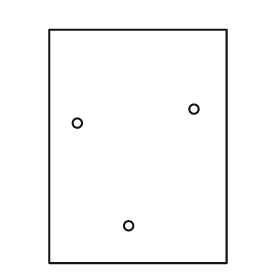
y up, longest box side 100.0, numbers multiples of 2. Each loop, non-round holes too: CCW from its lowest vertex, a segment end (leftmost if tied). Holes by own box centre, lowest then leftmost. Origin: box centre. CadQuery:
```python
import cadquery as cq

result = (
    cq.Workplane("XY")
    .moveTo(-38.0, -50.0)
    .lineTo(38.0, -50.0)
    .lineTo(38.0, 50.0)
    .lineTo(-38.0, 50.0)
    .close()
    .moveTo(-4.0, -34.0)
    .circle(2.0)
    .moveTo(-26.0, 10.0)
    .circle(2.0)
    .moveTo(24.0, 16.0)
    .circle(2.0)
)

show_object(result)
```